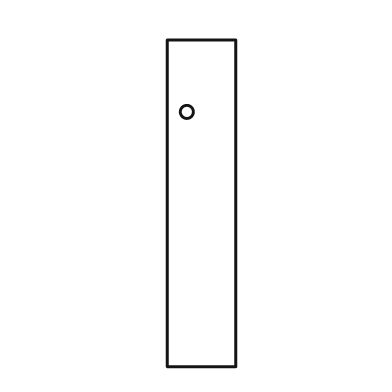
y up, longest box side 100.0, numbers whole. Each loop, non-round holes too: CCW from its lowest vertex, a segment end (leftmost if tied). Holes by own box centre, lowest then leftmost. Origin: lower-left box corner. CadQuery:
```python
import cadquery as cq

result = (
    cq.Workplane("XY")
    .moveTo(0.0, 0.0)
    .lineTo(21.0, 0.0)
    .lineTo(21.0, 100.0)
    .lineTo(0.0, 100.0)
    .close()
    .moveTo(6.0, 78.0)
    .circle(2.0)
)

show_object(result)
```